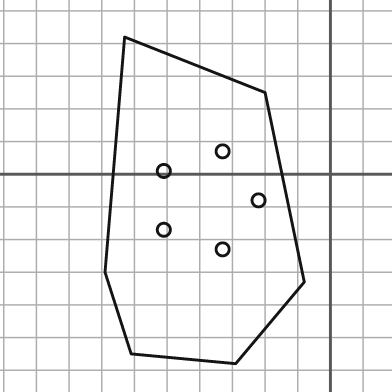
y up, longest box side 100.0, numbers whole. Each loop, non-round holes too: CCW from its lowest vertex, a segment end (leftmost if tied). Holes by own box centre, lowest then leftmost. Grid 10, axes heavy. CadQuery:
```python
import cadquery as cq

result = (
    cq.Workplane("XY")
    .moveTo(-29.0, -58.0)
    .lineTo(-8.0, -33.0)
    .lineTo(-20.0, 25.0)
    .lineTo(-63.0, 42.0)
    .lineTo(-69.0, -30.0)
    .lineTo(-61.0, -55.0)
    .close()
    .moveTo(-33.0, -23.0)
    .circle(2.0)
    .moveTo(-51.0, -17.0)
    .circle(2.0)
    .moveTo(-22.0, -8.0)
    .circle(2.0)
    .moveTo(-51.0, 1.0)
    .circle(2.0)
    .moveTo(-33.0, 7.0)
    .circle(2.0)
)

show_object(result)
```